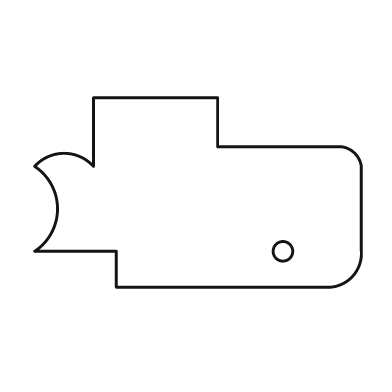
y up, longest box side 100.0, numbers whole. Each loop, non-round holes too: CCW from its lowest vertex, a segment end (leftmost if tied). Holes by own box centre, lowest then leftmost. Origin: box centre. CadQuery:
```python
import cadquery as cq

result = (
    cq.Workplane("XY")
    .moveTo(-25.0, -29.0)
    .lineTo(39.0, -29.0)
    .threePointArc((47.0, -26.0), (50.0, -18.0))
    .lineTo(50.0, 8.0)
    .threePointArc((48.0, 12.0), (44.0, 14.0))
    .lineTo(6.0, 14.0)
    .lineTo(6.0, 29.0)
    .lineTo(-32.0, 29.0)
    .lineTo(-32.0, 8.0)
    .threePointArc((-41.0, 12.0), (-50.0, 8.0))
    .threePointArc((-43.0, -5.0), (-50.0, -18.0))
    .lineTo(-25.0, -18.0)
    .close()
    .moveTo(26.0, -18.0)
    .circle(3.0)
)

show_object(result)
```